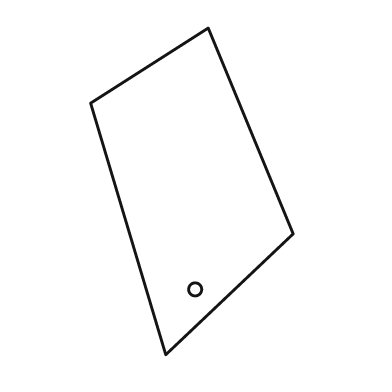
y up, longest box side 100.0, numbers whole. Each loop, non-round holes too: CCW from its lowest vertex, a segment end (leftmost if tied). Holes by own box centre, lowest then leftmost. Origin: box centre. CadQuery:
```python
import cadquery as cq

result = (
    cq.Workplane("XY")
    .moveTo(-8.0, -50.0)
    .lineTo(31.0, -13.0)
    .lineTo(5.0, 50.0)
    .lineTo(-31.0, 27.0)
    .close()
    .moveTo(1.0, -30.0)
    .circle(2.0)
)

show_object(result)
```